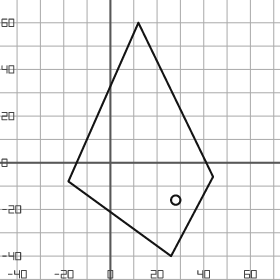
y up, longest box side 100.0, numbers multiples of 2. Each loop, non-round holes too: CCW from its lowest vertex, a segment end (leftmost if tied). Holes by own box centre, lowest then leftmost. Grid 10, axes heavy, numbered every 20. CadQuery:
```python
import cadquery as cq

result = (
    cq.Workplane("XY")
    .moveTo(26.0, -40.0)
    .lineTo(44.0, -6.0)
    .lineTo(12.0, 60.0)
    .lineTo(-18.0, -8.0)
    .close()
    .moveTo(28.0, -16.0)
    .circle(2.0)
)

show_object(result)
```